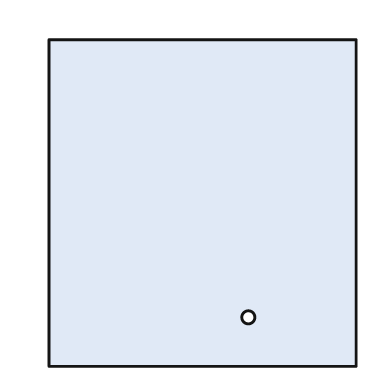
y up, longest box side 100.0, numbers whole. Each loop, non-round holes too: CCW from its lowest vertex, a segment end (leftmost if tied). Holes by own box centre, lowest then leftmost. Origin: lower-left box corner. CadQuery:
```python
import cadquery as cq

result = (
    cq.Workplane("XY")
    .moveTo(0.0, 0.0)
    .lineTo(94.0, 0.0)
    .lineTo(94.0, 100.0)
    .lineTo(0.0, 100.0)
    .close()
    .moveTo(61.0, 15.0)
    .circle(2.0)
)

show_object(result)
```